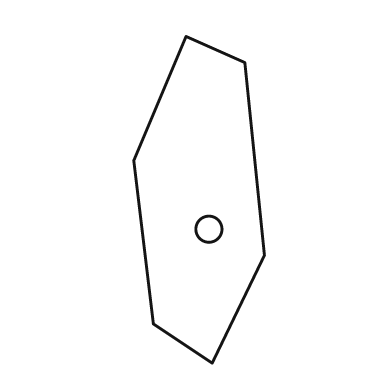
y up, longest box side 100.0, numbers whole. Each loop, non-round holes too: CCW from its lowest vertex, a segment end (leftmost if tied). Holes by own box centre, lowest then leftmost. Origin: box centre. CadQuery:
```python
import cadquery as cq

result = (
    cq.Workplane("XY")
    .moveTo(4.0, -50.0)
    .lineTo(20.0, -17.0)
    .lineTo(14.0, 42.0)
    .lineTo(-4.0, 50.0)
    .lineTo(-20.0, 12.0)
    .lineTo(-14.0, -38.0)
    .close()
    .moveTo(3.0, -9.0)
    .circle(4.0)
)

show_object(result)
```